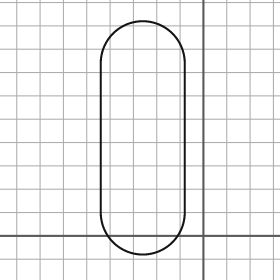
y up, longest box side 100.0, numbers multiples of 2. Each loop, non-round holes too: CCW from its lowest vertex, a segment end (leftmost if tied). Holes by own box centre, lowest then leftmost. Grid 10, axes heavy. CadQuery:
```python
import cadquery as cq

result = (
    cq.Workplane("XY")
    .moveTo(-44.0, 10.0)
    .threePointArc((-26.0, -8.0), (-8.0, 10.0))
    .lineTo(-8.0, 74.0)
    .threePointArc((-26.0, 92.0), (-44.0, 74.0))
    .close()
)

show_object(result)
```